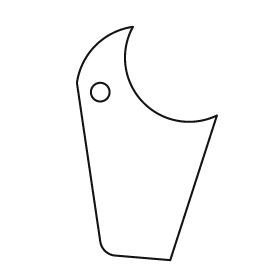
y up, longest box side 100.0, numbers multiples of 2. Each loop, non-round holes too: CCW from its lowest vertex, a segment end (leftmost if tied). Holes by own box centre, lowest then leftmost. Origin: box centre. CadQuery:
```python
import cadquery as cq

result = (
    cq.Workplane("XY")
    .moveTo(10.0, -50.0)
    .lineTo(30.0, 12.0)
    .threePointArc((-2.0, 18.0), (-6.0, 50.0))
    .threePointArc((-22.0, 42.0), (-30.0, 26.0))
    .lineTo(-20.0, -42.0)
    .threePointArc((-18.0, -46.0), (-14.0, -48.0))
    .close()
    .moveTo(-20.0, 22.0)
    .circle(4.0)
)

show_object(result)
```